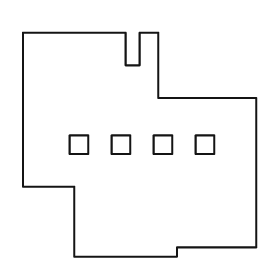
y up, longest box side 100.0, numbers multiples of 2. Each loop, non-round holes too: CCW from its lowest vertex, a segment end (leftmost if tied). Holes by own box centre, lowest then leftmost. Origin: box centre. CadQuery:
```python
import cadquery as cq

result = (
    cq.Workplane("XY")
    .moveTo(-28.0, -48.0)
    .lineTo(16.0, -48.0)
    .lineTo(16.0, -44.0)
    .lineTo(50.0, -44.0)
    .lineTo(50.0, 20.0)
    .lineTo(8.0, 20.0)
    .lineTo(8.0, 48.0)
    .lineTo(0.0, 48.0)
    .lineTo(0.0, 34.0)
    .lineTo(-6.0, 34.0)
    .lineTo(-6.0, 48.0)
    .lineTo(-50.0, 48.0)
    .lineTo(-50.0, -18.0)
    .lineTo(-28.0, -18.0)
    .close()
    .moveTo(-30.0, -4.0)
    .lineTo(-22.0, -4.0)
    .lineTo(-22.0, 4.0)
    .lineTo(-30.0, 4.0)
    .close()
    .moveTo(-12.0, -4.0)
    .lineTo(-4.0, -4.0)
    .lineTo(-4.0, 4.0)
    .lineTo(-12.0, 4.0)
    .close()
    .moveTo(6.0, -4.0)
    .lineTo(14.0, -4.0)
    .lineTo(14.0, 4.0)
    .lineTo(6.0, 4.0)
    .close()
    .moveTo(24.0, -4.0)
    .lineTo(32.0, -4.0)
    .lineTo(32.0, 4.0)
    .lineTo(24.0, 4.0)
    .close()
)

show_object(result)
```